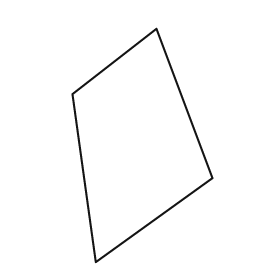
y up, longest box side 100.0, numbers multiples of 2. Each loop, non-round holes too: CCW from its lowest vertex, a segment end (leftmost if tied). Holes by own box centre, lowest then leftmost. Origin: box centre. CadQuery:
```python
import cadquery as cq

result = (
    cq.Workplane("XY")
    .moveTo(-20.0, -50.0)
    .lineTo(30.0, -14.0)
    .lineTo(6.0, 50.0)
    .lineTo(-30.0, 22.0)
    .close()
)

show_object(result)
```